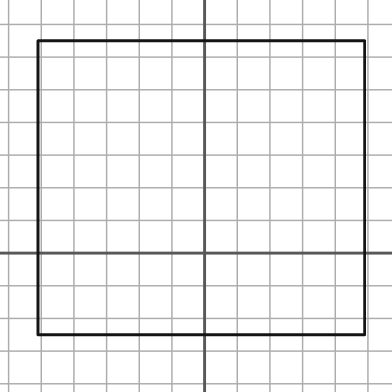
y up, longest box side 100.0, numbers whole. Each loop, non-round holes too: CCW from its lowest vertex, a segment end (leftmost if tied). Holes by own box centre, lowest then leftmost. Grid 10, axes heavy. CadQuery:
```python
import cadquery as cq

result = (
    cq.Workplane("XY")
    .moveTo(-51.0, -25.0)
    .lineTo(49.0, -25.0)
    .lineTo(49.0, 65.0)
    .lineTo(-51.0, 65.0)
    .close()
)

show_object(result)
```